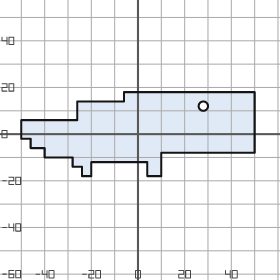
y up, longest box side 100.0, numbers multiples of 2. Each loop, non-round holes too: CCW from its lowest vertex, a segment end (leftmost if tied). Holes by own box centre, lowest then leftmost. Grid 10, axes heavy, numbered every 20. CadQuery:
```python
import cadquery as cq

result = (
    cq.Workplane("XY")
    .moveTo(-24.0, -18.0)
    .lineTo(-20.0, -18.0)
    .lineTo(-20.0, -12.0)
    .lineTo(4.0, -12.0)
    .lineTo(4.0, -18.0)
    .lineTo(10.0, -18.0)
    .lineTo(10.0, -8.0)
    .lineTo(50.0, -8.0)
    .lineTo(50.0, 18.0)
    .lineTo(-6.0, 18.0)
    .lineTo(-6.0, 14.0)
    .lineTo(-26.0, 14.0)
    .lineTo(-26.0, 6.0)
    .lineTo(-50.0, 6.0)
    .lineTo(-50.0, -2.0)
    .lineTo(-46.0, -2.0)
    .lineTo(-46.0, -6.0)
    .lineTo(-40.0, -6.0)
    .lineTo(-40.0, -10.0)
    .lineTo(-28.0, -10.0)
    .lineTo(-28.0, -14.0)
    .lineTo(-24.0, -14.0)
    .close()
    .moveTo(28.0, 12.0)
    .circle(2.0)
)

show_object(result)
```